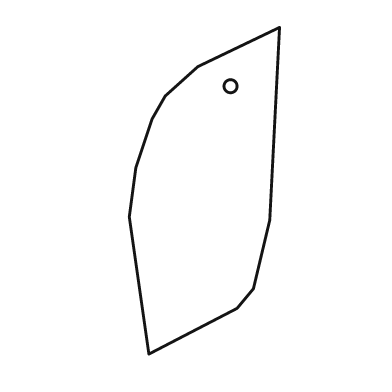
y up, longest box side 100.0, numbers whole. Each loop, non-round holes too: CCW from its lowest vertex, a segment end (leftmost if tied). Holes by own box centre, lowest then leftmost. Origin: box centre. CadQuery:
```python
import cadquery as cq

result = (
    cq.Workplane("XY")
    .moveTo(-17.0, -50.0)
    .lineTo(10.0, -36.0)
    .lineTo(15.0, -30.0)
    .lineTo(20.0, -9.0)
    .lineTo(23.0, 50.0)
    .lineTo(-2.0, 38.0)
    .lineTo(-12.0, 29.0)
    .lineTo(-16.0, 22.0)
    .lineTo(-21.0, 7.0)
    .lineTo(-23.0, -8.0)
    .close()
    .moveTo(8.0, 32.0)
    .circle(2.0)
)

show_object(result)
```